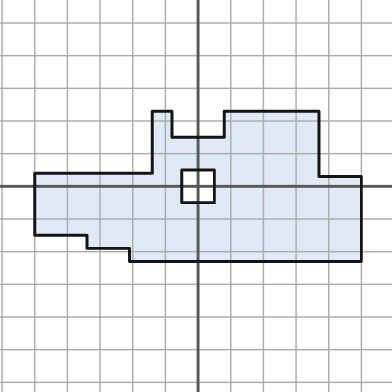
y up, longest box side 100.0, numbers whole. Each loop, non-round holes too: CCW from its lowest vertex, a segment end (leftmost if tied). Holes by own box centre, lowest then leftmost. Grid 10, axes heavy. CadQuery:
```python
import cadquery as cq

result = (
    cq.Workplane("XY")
    .moveTo(-21.0, -23.0)
    .lineTo(50.0, -23.0)
    .lineTo(50.0, 3.0)
    .lineTo(37.0, 3.0)
    .lineTo(37.0, 23.0)
    .lineTo(8.0, 23.0)
    .lineTo(8.0, 15.0)
    .lineTo(-8.0, 15.0)
    .lineTo(-8.0, 23.0)
    .lineTo(-14.0, 23.0)
    .lineTo(-14.0, 4.0)
    .lineTo(-50.0, 4.0)
    .lineTo(-50.0, -15.0)
    .lineTo(-34.0, -15.0)
    .lineTo(-34.0, -19.0)
    .lineTo(-21.0, -19.0)
    .close()
    .moveTo(-5.0, -5.0)
    .lineTo(5.0, -5.0)
    .lineTo(5.0, 5.0)
    .lineTo(-5.0, 5.0)
    .close()
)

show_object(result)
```